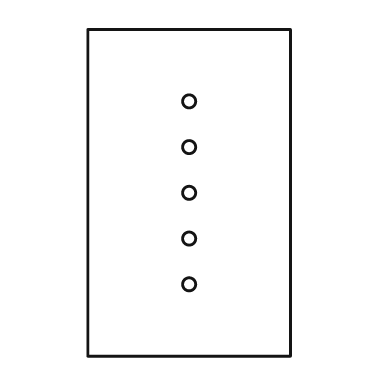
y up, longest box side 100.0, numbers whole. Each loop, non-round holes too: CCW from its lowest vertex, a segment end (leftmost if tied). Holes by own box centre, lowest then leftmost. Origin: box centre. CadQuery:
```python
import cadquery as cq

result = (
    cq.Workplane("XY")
    .moveTo(-31.0, -50.0)
    .lineTo(31.0, -50.0)
    .lineTo(31.0, 50.0)
    .lineTo(-31.0, 50.0)
    .close()
    .moveTo(0.0, -28.0)
    .circle(2.0)
    .moveTo(0.0, -14.0)
    .circle(2.0)
    .moveTo(0.0, 0.0)
    .circle(2.0)
    .moveTo(0.0, 14.0)
    .circle(2.0)
    .moveTo(0.0, 28.0)
    .circle(2.0)
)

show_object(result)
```